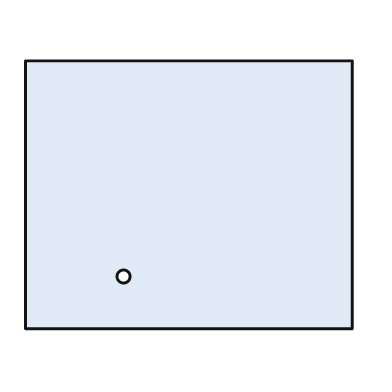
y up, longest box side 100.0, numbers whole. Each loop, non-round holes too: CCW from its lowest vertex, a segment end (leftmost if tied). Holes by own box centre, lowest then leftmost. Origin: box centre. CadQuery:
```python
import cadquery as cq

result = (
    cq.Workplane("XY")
    .moveTo(-50.0, -41.0)
    .lineTo(50.0, -41.0)
    .lineTo(50.0, 41.0)
    .lineTo(-50.0, 41.0)
    .close()
    .moveTo(-20.0, -25.0)
    .circle(2.0)
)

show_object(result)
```